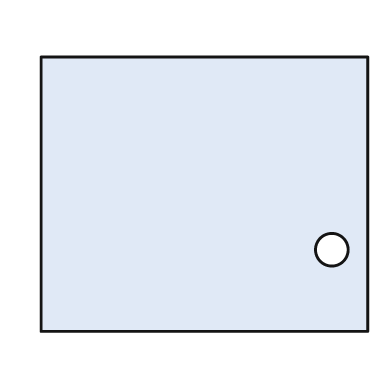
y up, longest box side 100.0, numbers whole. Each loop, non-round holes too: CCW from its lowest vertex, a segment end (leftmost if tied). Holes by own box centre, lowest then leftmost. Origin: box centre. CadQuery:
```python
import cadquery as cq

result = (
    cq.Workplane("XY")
    .moveTo(-50.0, -42.0)
    .lineTo(50.0, -42.0)
    .lineTo(50.0, 42.0)
    .lineTo(-50.0, 42.0)
    .close()
    .moveTo(39.0, -17.0)
    .circle(5.0)
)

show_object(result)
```